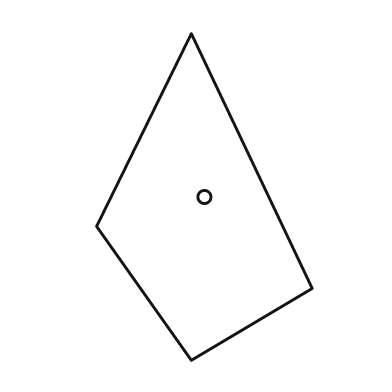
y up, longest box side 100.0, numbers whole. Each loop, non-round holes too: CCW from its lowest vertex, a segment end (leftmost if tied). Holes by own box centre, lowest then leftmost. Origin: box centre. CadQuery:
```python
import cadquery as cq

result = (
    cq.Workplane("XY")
    .moveTo(-4.0, -50.0)
    .lineTo(33.0, -28.0)
    .lineTo(-4.0, 50.0)
    .lineTo(-33.0, -9.0)
    .close()
    .moveTo(0.0, 0.0)
    .circle(2.0)
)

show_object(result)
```